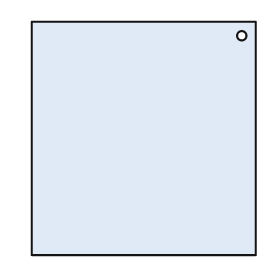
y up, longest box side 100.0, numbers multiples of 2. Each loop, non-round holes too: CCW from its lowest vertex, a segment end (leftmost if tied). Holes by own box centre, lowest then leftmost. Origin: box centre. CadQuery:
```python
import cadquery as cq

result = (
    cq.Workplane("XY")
    .moveTo(-48.0, -50.0)
    .lineTo(48.0, -50.0)
    .lineTo(48.0, 50.0)
    .lineTo(-48.0, 50.0)
    .close()
    .moveTo(42.0, 44.0)
    .circle(2.0)
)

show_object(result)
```